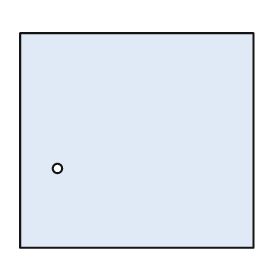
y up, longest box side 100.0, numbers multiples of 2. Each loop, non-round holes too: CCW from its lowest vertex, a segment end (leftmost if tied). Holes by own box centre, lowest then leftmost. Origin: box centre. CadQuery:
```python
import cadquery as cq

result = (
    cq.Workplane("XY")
    .moveTo(-50.0, -46.0)
    .lineTo(50.0, -46.0)
    .lineTo(50.0, 46.0)
    .lineTo(-50.0, 46.0)
    .close()
    .moveTo(-34.0, -12.0)
    .circle(2.0)
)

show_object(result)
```